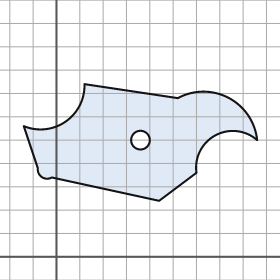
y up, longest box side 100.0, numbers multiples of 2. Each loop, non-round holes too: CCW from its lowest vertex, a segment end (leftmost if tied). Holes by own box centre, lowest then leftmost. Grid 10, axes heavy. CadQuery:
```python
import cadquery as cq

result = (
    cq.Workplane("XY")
    .moveTo(44.0, 24.0)
    .lineTo(60.0, 36.0)
    .threePointArc((68.0, 52.0), (86.0, 50.0))
    .threePointArc((74.0, 68.0), (52.0, 68.0))
    .lineTo(12.0, 74.0)
    .threePointArc((4.0, 58.0), (-14.0, 56.0))
    .lineTo(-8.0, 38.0)
    .threePointArc((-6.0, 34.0), (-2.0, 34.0))
    .close()
    .moveTo(36.0, 50.0)
    .circle(4.0)
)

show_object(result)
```